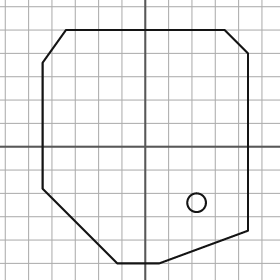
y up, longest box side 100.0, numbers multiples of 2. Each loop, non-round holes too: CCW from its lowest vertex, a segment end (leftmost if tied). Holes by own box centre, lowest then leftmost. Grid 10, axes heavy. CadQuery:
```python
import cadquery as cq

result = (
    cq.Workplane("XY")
    .moveTo(-12.0, -50.0)
    .lineTo(6.0, -50.0)
    .lineTo(44.0, -36.0)
    .lineTo(44.0, 40.0)
    .lineTo(34.0, 50.0)
    .lineTo(-34.0, 50.0)
    .lineTo(-44.0, 36.0)
    .lineTo(-44.0, -18.0)
    .close()
    .moveTo(22.0, -24.0)
    .circle(4.0)
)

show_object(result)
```